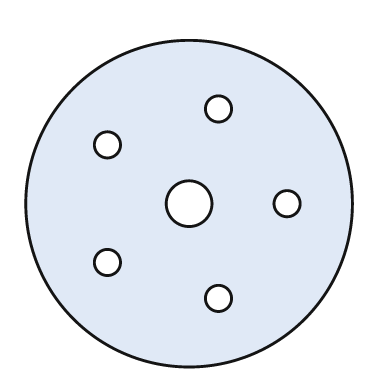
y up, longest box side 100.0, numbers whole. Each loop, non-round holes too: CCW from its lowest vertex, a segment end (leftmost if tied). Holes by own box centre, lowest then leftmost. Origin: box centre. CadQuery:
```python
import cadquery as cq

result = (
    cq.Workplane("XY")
    .moveTo(0.0, 0.0)
    .circle(50.0)
    .moveTo(9.0, -29.0)
    .circle(4.0)
    .moveTo(-25.0, -18.0)
    .circle(4.0)
    .moveTo(0.0, 0.0)
    .circle(7.0)
    .moveTo(30.0, 0.0)
    .circle(4.0)
    .moveTo(-25.0, 18.0)
    .circle(4.0)
    .moveTo(9.0, 29.0)
    .circle(4.0)
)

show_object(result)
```